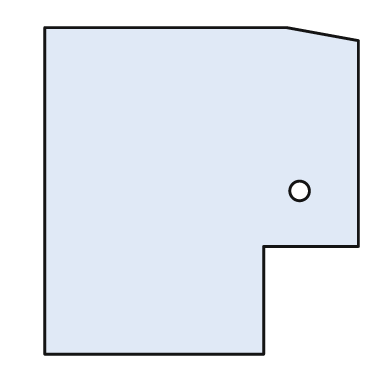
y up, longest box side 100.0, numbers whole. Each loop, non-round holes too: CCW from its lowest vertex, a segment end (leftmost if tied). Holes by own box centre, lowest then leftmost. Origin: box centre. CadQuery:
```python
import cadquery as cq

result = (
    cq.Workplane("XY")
    .moveTo(-48.0, -50.0)
    .lineTo(19.0, -50.0)
    .lineTo(19.0, -17.0)
    .lineTo(48.0, -17.0)
    .lineTo(48.0, 46.0)
    .lineTo(26.0, 50.0)
    .lineTo(-48.0, 50.0)
    .close()
    .moveTo(30.0, 0.0)
    .circle(3.0)
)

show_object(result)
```